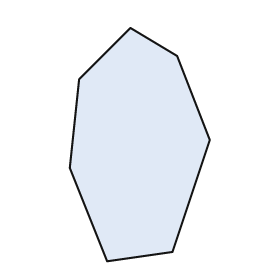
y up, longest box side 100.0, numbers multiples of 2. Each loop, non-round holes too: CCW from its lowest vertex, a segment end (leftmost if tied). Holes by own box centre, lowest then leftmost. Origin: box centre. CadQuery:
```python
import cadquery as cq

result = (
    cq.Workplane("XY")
    .moveTo(-14.0, -50.0)
    .lineTo(14.0, -46.0)
    .lineTo(30.0, 2.0)
    .lineTo(16.0, 38.0)
    .lineTo(-4.0, 50.0)
    .lineTo(-26.0, 28.0)
    .lineTo(-30.0, -10.0)
    .close()
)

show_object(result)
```